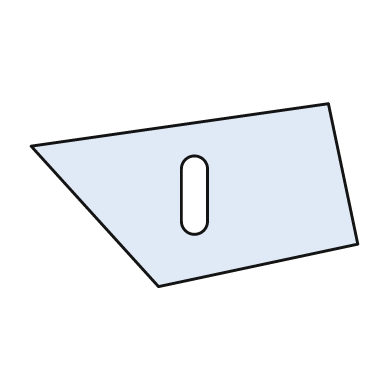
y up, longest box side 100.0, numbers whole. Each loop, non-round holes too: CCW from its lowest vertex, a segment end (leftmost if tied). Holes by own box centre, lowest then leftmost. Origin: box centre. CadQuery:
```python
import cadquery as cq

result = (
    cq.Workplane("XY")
    .moveTo(-11.0, -28.0)
    .lineTo(50.0, -15.0)
    .lineTo(41.0, 28.0)
    .lineTo(-50.0, 15.0)
    .close()
    .moveTo(-4.0, -8.0)
    .threePointArc((0.0, -12.0), (4.0, -8.0))
    .lineTo(4.0, 8.0)
    .threePointArc((0.0, 12.0), (-4.0, 8.0))
    .close()
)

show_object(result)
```